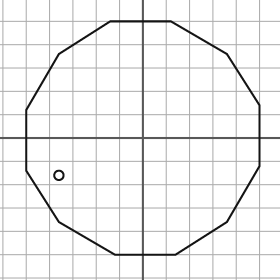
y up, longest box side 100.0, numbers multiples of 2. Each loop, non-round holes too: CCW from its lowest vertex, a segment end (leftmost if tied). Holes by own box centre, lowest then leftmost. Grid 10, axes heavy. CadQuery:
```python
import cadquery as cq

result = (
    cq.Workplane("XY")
    .moveTo(-12.0, -50.0)
    .lineTo(14.0, -50.0)
    .lineTo(36.0, -36.0)
    .lineTo(50.0, -12.0)
    .lineTo(50.0, 14.0)
    .lineTo(36.0, 36.0)
    .lineTo(12.0, 50.0)
    .lineTo(-14.0, 50.0)
    .lineTo(-36.0, 36.0)
    .lineTo(-50.0, 12.0)
    .lineTo(-50.0, -14.0)
    .lineTo(-36.0, -36.0)
    .close()
    .moveTo(-36.0, -16.0)
    .circle(2.0)
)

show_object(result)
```